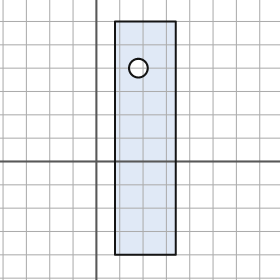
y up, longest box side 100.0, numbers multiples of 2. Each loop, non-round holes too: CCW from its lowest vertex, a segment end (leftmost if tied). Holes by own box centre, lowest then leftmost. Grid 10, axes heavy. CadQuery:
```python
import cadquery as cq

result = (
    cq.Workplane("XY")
    .moveTo(8.0, -40.0)
    .lineTo(34.0, -40.0)
    .lineTo(34.0, 60.0)
    .lineTo(8.0, 60.0)
    .close()
    .moveTo(18.0, 40.0)
    .circle(4.0)
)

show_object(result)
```